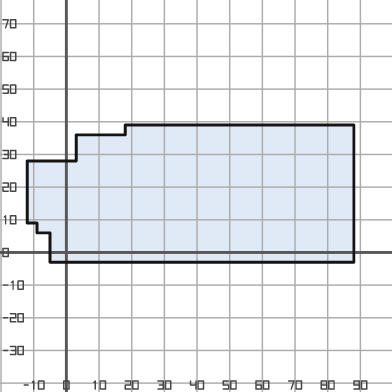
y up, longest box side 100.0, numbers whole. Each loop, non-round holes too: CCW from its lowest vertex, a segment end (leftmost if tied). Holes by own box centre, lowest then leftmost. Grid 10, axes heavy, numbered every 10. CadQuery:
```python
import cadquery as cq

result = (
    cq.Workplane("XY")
    .moveTo(-5.0, -3.0)
    .lineTo(88.0, -3.0)
    .lineTo(88.0, 39.0)
    .lineTo(18.0, 39.0)
    .lineTo(18.0, 36.0)
    .lineTo(3.0, 36.0)
    .lineTo(3.0, 28.0)
    .lineTo(-12.0, 28.0)
    .lineTo(-12.0, 9.0)
    .lineTo(-9.0, 9.0)
    .lineTo(-9.0, 6.0)
    .lineTo(-5.0, 6.0)
    .close()
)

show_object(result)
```